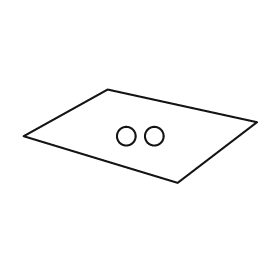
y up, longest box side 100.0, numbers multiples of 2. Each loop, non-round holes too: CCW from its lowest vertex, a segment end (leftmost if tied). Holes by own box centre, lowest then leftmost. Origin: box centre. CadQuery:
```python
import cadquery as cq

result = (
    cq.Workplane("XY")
    .moveTo(16.0, -20.0)
    .lineTo(50.0, 6.0)
    .lineTo(-14.0, 20.0)
    .lineTo(-50.0, 0.0)
    .close()
    .moveTo(-6.0, 0.0)
    .circle(4.0)
    .moveTo(6.0, 0.0)
    .circle(4.0)
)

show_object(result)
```